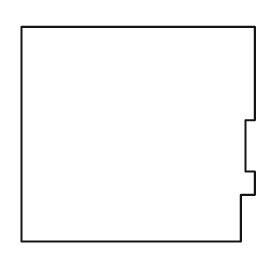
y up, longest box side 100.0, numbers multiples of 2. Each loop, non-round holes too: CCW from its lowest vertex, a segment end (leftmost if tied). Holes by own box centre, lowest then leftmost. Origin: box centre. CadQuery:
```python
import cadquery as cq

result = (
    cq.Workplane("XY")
    .moveTo(-50.0, -46.0)
    .lineTo(44.0, -46.0)
    .lineTo(44.0, -26.0)
    .lineTo(50.0, -26.0)
    .lineTo(50.0, -16.0)
    .lineTo(46.0, -16.0)
    .lineTo(46.0, 6.0)
    .lineTo(50.0, 6.0)
    .lineTo(50.0, 46.0)
    .lineTo(-50.0, 46.0)
    .close()
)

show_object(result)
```